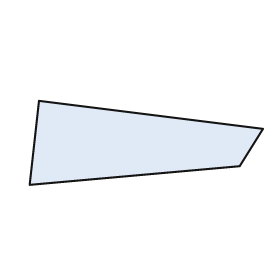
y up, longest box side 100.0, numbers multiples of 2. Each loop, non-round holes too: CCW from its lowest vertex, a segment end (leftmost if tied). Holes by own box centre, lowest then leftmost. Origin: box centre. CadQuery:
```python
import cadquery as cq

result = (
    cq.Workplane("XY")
    .moveTo(-50.0, -18.0)
    .lineTo(40.0, -10.0)
    .lineTo(50.0, 6.0)
    .lineTo(-46.0, 18.0)
    .close()
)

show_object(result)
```